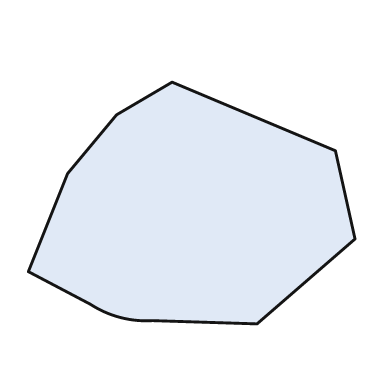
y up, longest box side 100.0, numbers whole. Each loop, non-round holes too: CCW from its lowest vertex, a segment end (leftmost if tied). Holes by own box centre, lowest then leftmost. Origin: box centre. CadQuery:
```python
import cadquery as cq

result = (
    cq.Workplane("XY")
    .moveTo(20.0, -37.0)
    .lineTo(50.0, -11.0)
    .lineTo(44.0, 16.0)
    .lineTo(-6.0, 37.0)
    .lineTo(-23.0, 27.0)
    .lineTo(-38.0, 9.0)
    .lineTo(-50.0, -21.0)
    .lineTo(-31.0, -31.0)
    .threePointArc((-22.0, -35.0), (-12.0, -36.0))
    .close()
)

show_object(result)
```